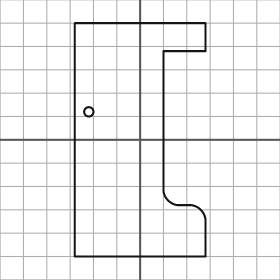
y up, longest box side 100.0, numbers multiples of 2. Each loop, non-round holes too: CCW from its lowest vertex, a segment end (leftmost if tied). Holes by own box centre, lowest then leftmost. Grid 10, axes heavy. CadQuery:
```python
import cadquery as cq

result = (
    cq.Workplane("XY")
    .moveTo(-28.0, -50.0)
    .lineTo(28.0, -50.0)
    .lineTo(28.0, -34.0)
    .threePointArc((26.0, -30.0), (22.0, -28.0))
    .lineTo(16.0, -28.0)
    .threePointArc((12.0, -26.0), (10.0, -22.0))
    .lineTo(10.0, 38.0)
    .lineTo(28.0, 38.0)
    .lineTo(28.0, 50.0)
    .lineTo(-28.0, 50.0)
    .close()
    .moveTo(-22.0, 12.0)
    .circle(2.0)
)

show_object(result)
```